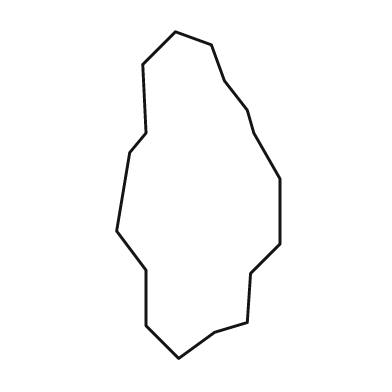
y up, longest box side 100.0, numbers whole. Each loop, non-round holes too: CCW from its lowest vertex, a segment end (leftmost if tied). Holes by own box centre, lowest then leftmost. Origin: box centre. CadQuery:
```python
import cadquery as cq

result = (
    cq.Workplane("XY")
    .moveTo(-6.0, -50.0)
    .lineTo(5.0, -42.0)
    .lineTo(15.0, -39.0)
    .lineTo(16.0, -24.0)
    .lineTo(25.0, -15.0)
    .lineTo(25.0, 5.0)
    .lineTo(17.0, 19.0)
    .lineTo(15.0, 26.0)
    .lineTo(8.0, 35.0)
    .lineTo(4.0, 46.0)
    .lineTo(-7.0, 50.0)
    .lineTo(-17.0, 40.0)
    .lineTo(-16.0, 19.0)
    .lineTo(-21.0, 13.0)
    .lineTo(-25.0, -11.0)
    .lineTo(-16.0, -23.0)
    .lineTo(-16.0, -40.0)
    .close()
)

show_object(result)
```